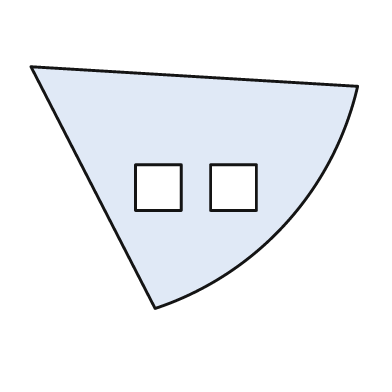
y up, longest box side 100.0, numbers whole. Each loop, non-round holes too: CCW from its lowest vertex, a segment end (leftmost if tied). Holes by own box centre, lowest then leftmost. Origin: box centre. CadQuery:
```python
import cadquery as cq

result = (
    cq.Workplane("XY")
    .moveTo(-12.0, -37.0)
    .threePointArc((28.0, -11.0), (50.0, 31.0))
    .lineTo(-50.0, 37.0)
    .close()
    .moveTo(-18.0, -7.0)
    .lineTo(-4.0, -7.0)
    .lineTo(-4.0, 7.0)
    .lineTo(-18.0, 7.0)
    .close()
    .moveTo(5.0, -7.0)
    .lineTo(19.0, -7.0)
    .lineTo(19.0, 7.0)
    .lineTo(5.0, 7.0)
    .close()
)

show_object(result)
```